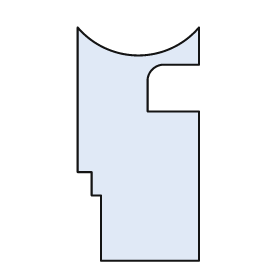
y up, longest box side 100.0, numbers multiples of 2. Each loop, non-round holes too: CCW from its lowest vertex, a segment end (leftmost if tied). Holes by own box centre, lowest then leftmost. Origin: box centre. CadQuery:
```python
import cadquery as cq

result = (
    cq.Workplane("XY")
    .moveTo(-16.0, -50.0)
    .lineTo(26.0, -50.0)
    .lineTo(26.0, 14.0)
    .lineTo(4.0, 14.0)
    .lineTo(4.0, 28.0)
    .threePointArc((6.0, 32.0), (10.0, 34.0))
    .lineTo(26.0, 34.0)
    .lineTo(26.0, 50.0)
    .threePointArc((0.0, 38.0), (-26.0, 50.0))
    .lineTo(-26.0, -12.0)
    .lineTo(-20.0, -12.0)
    .lineTo(-20.0, -22.0)
    .lineTo(-16.0, -22.0)
    .close()
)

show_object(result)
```